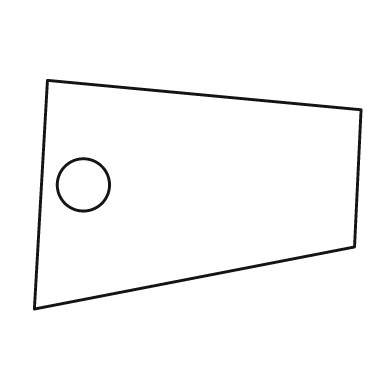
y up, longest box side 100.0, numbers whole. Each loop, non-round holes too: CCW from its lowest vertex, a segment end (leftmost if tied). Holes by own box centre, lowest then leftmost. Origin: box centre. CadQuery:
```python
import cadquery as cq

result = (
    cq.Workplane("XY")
    .moveTo(-50.0, -35.0)
    .lineTo(48.0, -16.0)
    .lineTo(50.0, 26.0)
    .lineTo(-46.0, 35.0)
    .close()
    .moveTo(-35.0, 3.0)
    .circle(8.0)
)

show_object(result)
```